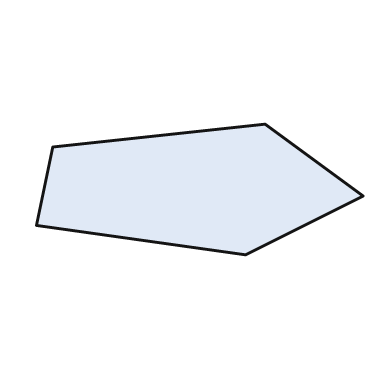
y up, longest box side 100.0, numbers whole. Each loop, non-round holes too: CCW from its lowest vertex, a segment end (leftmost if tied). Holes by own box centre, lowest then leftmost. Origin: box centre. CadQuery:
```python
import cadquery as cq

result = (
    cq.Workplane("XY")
    .moveTo(14.0, -20.0)
    .lineTo(50.0, -2.0)
    .lineTo(20.0, 20.0)
    .lineTo(-45.0, 13.0)
    .lineTo(-50.0, -11.0)
    .close()
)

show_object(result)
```